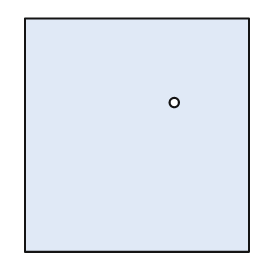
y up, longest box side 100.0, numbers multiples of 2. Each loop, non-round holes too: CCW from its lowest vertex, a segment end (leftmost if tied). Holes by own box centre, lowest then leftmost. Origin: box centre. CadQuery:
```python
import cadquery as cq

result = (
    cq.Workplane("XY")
    .moveTo(-48.0, -50.0)
    .lineTo(48.0, -50.0)
    .lineTo(48.0, 50.0)
    .lineTo(-48.0, 50.0)
    .close()
    .moveTo(16.0, 14.0)
    .circle(2.0)
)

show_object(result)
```